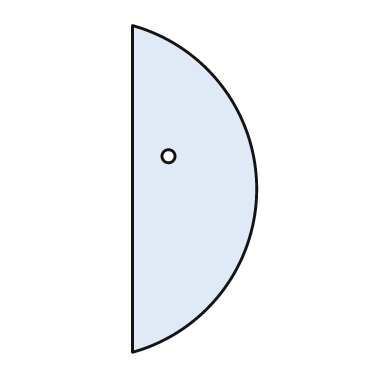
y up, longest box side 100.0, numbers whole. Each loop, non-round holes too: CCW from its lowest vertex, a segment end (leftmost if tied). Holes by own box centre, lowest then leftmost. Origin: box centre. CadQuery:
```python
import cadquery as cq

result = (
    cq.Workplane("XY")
    .moveTo(-19.0, -50.0)
    .threePointArc((19.0, 0.0), (-19.0, 50.0))
    .close()
    .moveTo(-8.0, 10.0)
    .circle(2.0)
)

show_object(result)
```